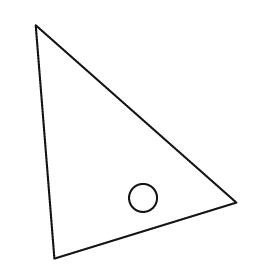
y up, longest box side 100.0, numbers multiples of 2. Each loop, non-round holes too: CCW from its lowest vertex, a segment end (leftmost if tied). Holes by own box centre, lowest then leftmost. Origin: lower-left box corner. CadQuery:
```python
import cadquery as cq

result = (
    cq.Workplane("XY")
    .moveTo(8.0, 0.0)
    .lineTo(86.0, 24.0)
    .lineTo(0.0, 100.0)
    .close()
    .moveTo(46.0, 26.0)
    .circle(6.0)
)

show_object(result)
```